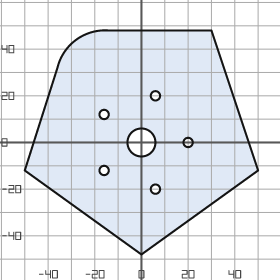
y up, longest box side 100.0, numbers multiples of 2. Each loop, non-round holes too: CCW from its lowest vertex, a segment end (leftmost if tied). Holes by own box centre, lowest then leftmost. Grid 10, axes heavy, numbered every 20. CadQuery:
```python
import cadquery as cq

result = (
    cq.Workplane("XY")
    .moveTo(0.0, -48.0)
    .lineTo(50.0, -12.0)
    .lineTo(30.0, 48.0)
    .lineTo(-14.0, 48.0)
    .threePointArc((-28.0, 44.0), (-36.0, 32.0))
    .lineTo(-50.0, -12.0)
    .close()
    .moveTo(6.0, -20.0)
    .circle(2.0)
    .moveTo(-16.0, -12.0)
    .circle(2.0)
    .moveTo(0.0, 0.0)
    .circle(6.0)
    .moveTo(20.0, 0.0)
    .circle(2.0)
    .moveTo(-16.0, 12.0)
    .circle(2.0)
    .moveTo(6.0, 20.0)
    .circle(2.0)
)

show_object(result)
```